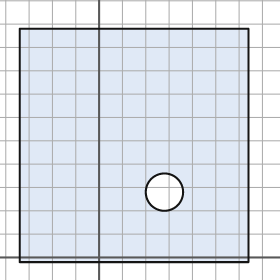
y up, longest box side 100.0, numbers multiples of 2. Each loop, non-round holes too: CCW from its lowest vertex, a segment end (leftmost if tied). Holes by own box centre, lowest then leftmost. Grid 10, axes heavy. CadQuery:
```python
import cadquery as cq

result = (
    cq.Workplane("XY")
    .moveTo(-34.0, -2.0)
    .lineTo(64.0, -2.0)
    .lineTo(64.0, 98.0)
    .lineTo(-34.0, 98.0)
    .close()
    .moveTo(28.0, 28.0)
    .circle(8.0)
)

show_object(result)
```